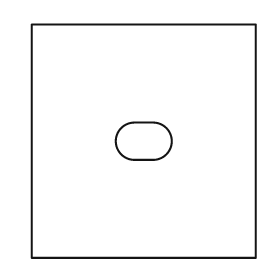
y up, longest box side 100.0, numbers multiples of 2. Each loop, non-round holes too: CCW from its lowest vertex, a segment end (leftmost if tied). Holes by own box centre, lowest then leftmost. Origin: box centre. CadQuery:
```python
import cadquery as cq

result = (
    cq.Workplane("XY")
    .moveTo(-48.0, -50.0)
    .lineTo(48.0, -50.0)
    .lineTo(48.0, 50.0)
    .lineTo(-48.0, 50.0)
    .close()
    .moveTo(-4.0, -8.0)
    .lineTo(4.0, -8.0)
    .threePointArc((12.0, 0.0), (4.0, 8.0))
    .lineTo(-4.0, 8.0)
    .threePointArc((-12.0, 0.0), (-4.0, -8.0))
    .close()
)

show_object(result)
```